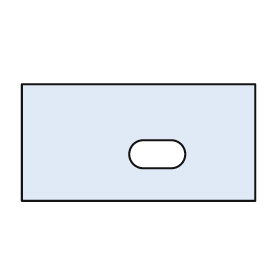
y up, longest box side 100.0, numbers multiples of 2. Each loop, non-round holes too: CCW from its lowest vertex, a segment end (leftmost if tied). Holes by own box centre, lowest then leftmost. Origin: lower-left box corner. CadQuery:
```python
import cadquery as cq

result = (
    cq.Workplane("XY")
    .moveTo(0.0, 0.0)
    .lineTo(100.0, 0.0)
    .lineTo(100.0, 50.0)
    .lineTo(0.0, 50.0)
    .close()
    .moveTo(52.0, 14.0)
    .lineTo(64.0, 14.0)
    .threePointArc((70.0, 20.0), (64.0, 26.0))
    .lineTo(52.0, 26.0)
    .threePointArc((46.0, 20.0), (52.0, 14.0))
    .close()
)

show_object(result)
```